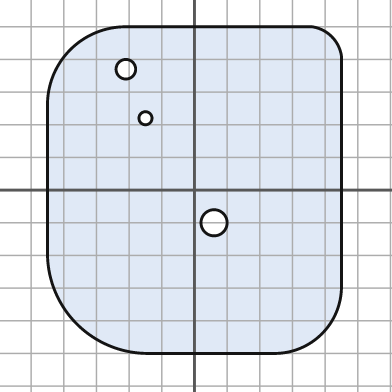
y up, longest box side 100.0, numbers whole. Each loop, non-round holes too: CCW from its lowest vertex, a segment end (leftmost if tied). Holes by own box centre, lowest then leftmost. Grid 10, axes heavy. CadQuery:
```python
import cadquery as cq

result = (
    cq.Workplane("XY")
    .moveTo(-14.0, -50.0)
    .lineTo(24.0, -50.0)
    .threePointArc((39.0, -44.0), (45.0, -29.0))
    .lineTo(45.0, 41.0)
    .threePointArc((42.0, 47.0), (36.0, 50.0))
    .lineTo(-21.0, 50.0)
    .threePointArc((-38.0, 43.0), (-45.0, 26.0))
    .lineTo(-45.0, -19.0)
    .threePointArc((-36.0, -41.0), (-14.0, -50.0))
    .close()
    .moveTo(6.0, -10.0)
    .circle(4.0)
    .moveTo(-15.0, 22.0)
    .circle(2.0)
    .moveTo(-21.0, 37.0)
    .circle(3.0)
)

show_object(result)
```